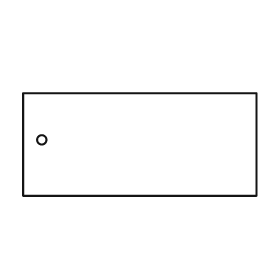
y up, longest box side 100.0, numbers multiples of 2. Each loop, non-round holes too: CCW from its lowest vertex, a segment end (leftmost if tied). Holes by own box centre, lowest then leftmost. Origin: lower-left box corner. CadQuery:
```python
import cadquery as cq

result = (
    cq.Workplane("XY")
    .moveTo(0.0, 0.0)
    .lineTo(100.0, 0.0)
    .lineTo(100.0, 44.0)
    .lineTo(0.0, 44.0)
    .close()
    .moveTo(8.0, 24.0)
    .circle(2.0)
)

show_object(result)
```